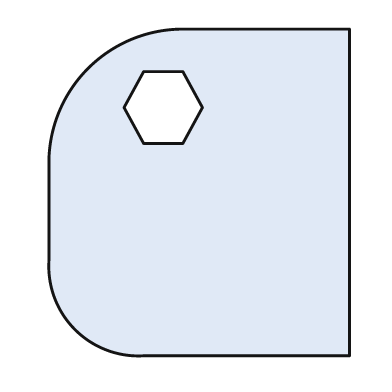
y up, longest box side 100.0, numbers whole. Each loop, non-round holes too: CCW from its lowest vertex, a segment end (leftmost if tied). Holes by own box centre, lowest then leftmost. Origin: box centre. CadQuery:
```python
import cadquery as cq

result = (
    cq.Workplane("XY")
    .moveTo(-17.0, -50.0)
    .lineTo(46.0, -50.0)
    .lineTo(46.0, 50.0)
    .lineTo(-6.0, 50.0)
    .threePointArc((-34.0, 38.0), (-46.0, 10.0))
    .lineTo(-46.0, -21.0)
    .threePointArc((-38.0, -42.0), (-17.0, -50.0))
    .close()
    .moveTo(-17.0, 15.0)
    .lineTo(-5.0, 15.0)
    .lineTo(1.0, 26.0)
    .lineTo(-5.0, 37.0)
    .lineTo(-17.0, 37.0)
    .lineTo(-23.0, 26.0)
    .close()
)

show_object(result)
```